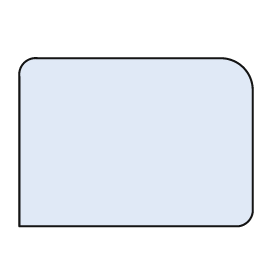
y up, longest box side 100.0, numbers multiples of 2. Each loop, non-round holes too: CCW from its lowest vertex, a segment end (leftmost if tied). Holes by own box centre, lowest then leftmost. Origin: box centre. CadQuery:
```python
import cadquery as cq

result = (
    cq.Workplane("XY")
    .moveTo(-50.0, -36.0)
    .lineTo(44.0, -36.0)
    .threePointArc((48.0, -34.0), (50.0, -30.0))
    .lineTo(50.0, 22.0)
    .threePointArc((46.0, 32.0), (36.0, 36.0))
    .lineTo(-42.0, 36.0)
    .threePointArc((-48.0, 34.0), (-50.0, 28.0))
    .close()
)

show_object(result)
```